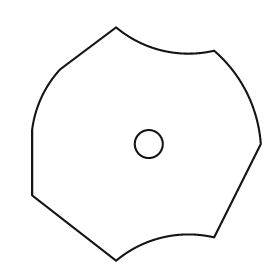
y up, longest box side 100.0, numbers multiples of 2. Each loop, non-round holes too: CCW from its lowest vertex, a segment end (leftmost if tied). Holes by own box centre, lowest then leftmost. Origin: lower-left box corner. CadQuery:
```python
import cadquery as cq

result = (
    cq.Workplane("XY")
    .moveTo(36.0, 0.0)
    .threePointArc((56.0, 10.0), (78.0, 10.0))
    .lineTo(98.0, 50.0)
    .threePointArc((92.0, 72.0), (78.0, 90.0))
    .threePointArc((56.0, 90.0), (36.0, 100.0))
    .lineTo(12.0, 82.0)
    .threePointArc((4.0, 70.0), (0.0, 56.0))
    .lineTo(0.0, 28.0)
    .close()
    .moveTo(50.0, 50.0)
    .circle(6.0)
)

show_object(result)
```